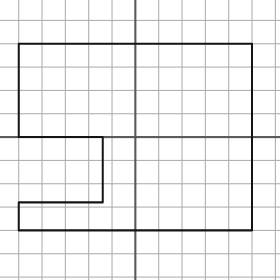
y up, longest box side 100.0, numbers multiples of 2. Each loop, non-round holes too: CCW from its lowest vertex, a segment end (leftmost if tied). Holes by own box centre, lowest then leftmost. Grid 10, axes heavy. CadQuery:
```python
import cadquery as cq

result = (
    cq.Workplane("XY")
    .moveTo(-50.0, -40.0)
    .lineTo(50.0, -40.0)
    .lineTo(50.0, 40.0)
    .lineTo(-50.0, 40.0)
    .lineTo(-50.0, 0.0)
    .lineTo(-14.0, 0.0)
    .lineTo(-14.0, -28.0)
    .lineTo(-50.0, -28.0)
    .close()
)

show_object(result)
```